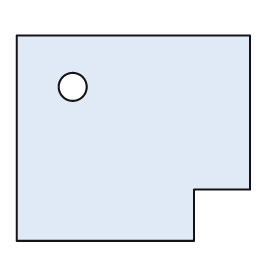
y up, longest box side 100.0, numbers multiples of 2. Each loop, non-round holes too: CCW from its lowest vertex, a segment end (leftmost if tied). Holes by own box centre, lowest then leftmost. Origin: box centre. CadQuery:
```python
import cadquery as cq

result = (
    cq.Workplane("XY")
    .moveTo(-50.0, -44.0)
    .lineTo(26.0, -44.0)
    .lineTo(26.0, -22.0)
    .lineTo(50.0, -22.0)
    .lineTo(50.0, 44.0)
    .lineTo(-50.0, 44.0)
    .close()
    .moveTo(-26.0, 22.0)
    .circle(6.0)
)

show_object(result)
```